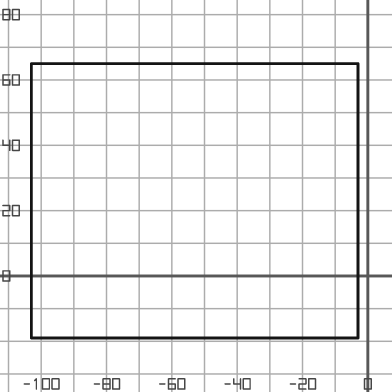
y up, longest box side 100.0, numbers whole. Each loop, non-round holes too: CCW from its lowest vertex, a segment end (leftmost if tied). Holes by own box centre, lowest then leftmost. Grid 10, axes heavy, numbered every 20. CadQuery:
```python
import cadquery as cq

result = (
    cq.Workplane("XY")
    .moveTo(-103.0, -19.0)
    .lineTo(-3.0, -19.0)
    .lineTo(-3.0, 65.0)
    .lineTo(-103.0, 65.0)
    .close()
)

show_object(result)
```